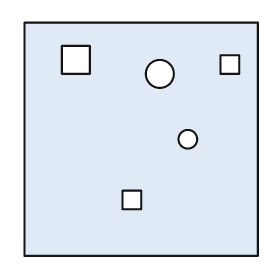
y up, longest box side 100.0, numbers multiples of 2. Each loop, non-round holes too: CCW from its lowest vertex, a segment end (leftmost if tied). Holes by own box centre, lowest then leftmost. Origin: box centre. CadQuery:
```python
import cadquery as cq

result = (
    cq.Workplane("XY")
    .moveTo(-50.0, -50.0)
    .lineTo(50.0, -50.0)
    .lineTo(50.0, 50.0)
    .lineTo(-50.0, 50.0)
    .close()
    .moveTo(-8.0, -30.0)
    .lineTo(0.0, -30.0)
    .lineTo(0.0, -22.0)
    .lineTo(-8.0, -22.0)
    .close()
    .moveTo(20.0, 0.0)
    .circle(4.0)
    .moveTo(8.0, 28.0)
    .circle(6.0)
    .moveTo(34.0, 28.0)
    .lineTo(42.0, 28.0)
    .lineTo(42.0, 36.0)
    .lineTo(34.0, 36.0)
    .close()
    .moveTo(-34.0, 28.0)
    .lineTo(-22.0, 28.0)
    .lineTo(-22.0, 40.0)
    .lineTo(-34.0, 40.0)
    .close()
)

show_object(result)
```